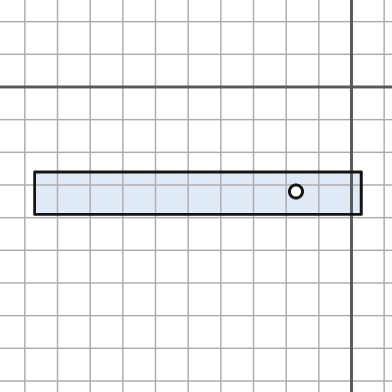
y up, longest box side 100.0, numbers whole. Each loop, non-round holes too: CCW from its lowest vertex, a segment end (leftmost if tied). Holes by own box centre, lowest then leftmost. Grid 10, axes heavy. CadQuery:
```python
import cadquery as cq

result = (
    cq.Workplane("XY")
    .moveTo(-97.0, -39.0)
    .lineTo(3.0, -39.0)
    .lineTo(3.0, -26.0)
    .lineTo(-97.0, -26.0)
    .close()
    .moveTo(-17.0, -32.0)
    .circle(2.0)
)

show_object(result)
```